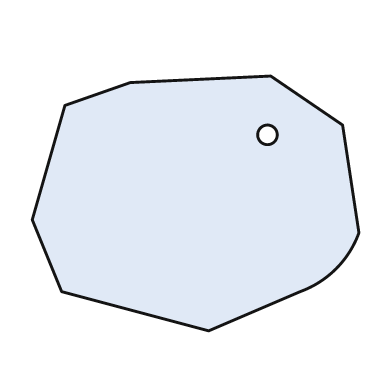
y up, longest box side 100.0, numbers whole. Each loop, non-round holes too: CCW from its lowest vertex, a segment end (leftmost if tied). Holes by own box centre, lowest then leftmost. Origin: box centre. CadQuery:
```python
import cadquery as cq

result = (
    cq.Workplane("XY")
    .moveTo(4.0, -39.0)
    .lineTo(32.0, -27.0)
    .threePointArc((43.0, -20.0), (50.0, -9.0))
    .lineTo(45.0, 24.0)
    .lineTo(23.0, 39.0)
    .lineTo(-20.0, 37.0)
    .lineTo(-40.0, 30.0)
    .lineTo(-50.0, -5.0)
    .lineTo(-41.0, -27.0)
    .close()
    .moveTo(22.0, 21.0)
    .circle(3.0)
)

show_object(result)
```